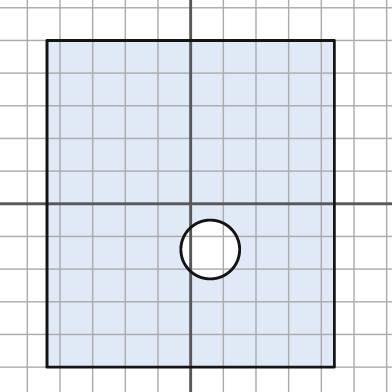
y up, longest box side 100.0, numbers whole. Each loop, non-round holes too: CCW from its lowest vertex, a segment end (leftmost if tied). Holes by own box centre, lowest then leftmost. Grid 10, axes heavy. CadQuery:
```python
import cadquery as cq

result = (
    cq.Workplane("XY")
    .moveTo(-44.0, -50.0)
    .lineTo(44.0, -50.0)
    .lineTo(44.0, 50.0)
    .lineTo(-44.0, 50.0)
    .close()
    .moveTo(6.0, -14.0)
    .circle(9.0)
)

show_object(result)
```